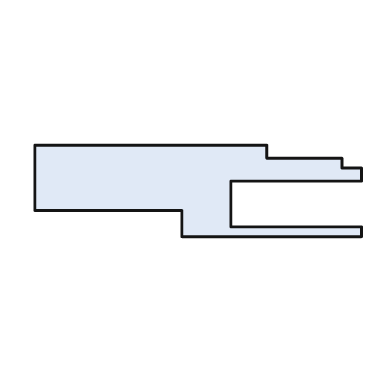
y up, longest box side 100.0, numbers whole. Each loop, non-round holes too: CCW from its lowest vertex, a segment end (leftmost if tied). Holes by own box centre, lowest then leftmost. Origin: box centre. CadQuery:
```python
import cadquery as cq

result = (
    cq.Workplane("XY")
    .moveTo(-5.0, -14.0)
    .lineTo(50.0, -14.0)
    .lineTo(50.0, -11.0)
    .lineTo(10.0, -11.0)
    .lineTo(10.0, 3.0)
    .lineTo(50.0, 3.0)
    .lineTo(50.0, 7.0)
    .lineTo(44.0, 7.0)
    .lineTo(44.0, 10.0)
    .lineTo(21.0, 10.0)
    .lineTo(21.0, 14.0)
    .lineTo(-50.0, 14.0)
    .lineTo(-50.0, -6.0)
    .lineTo(-5.0, -6.0)
    .close()
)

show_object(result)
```